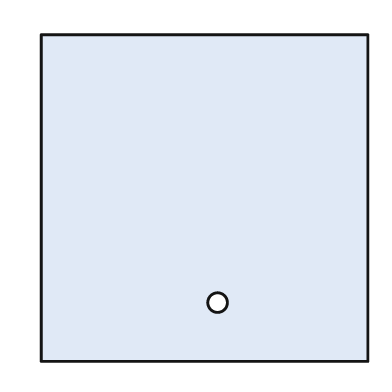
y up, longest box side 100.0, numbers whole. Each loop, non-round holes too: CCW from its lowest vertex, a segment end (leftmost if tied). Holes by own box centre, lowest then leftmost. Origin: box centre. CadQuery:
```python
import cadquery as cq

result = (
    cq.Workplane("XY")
    .moveTo(-50.0, -50.0)
    .lineTo(50.0, -50.0)
    .lineTo(50.0, 50.0)
    .lineTo(-50.0, 50.0)
    .close()
    .moveTo(4.0, -32.0)
    .circle(3.0)
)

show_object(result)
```